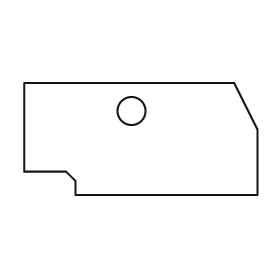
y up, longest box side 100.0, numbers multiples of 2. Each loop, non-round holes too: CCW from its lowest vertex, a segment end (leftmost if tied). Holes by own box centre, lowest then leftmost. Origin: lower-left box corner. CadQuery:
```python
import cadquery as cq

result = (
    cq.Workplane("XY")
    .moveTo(22.0, 0.0)
    .lineTo(100.0, 0.0)
    .lineTo(100.0, 28.0)
    .lineTo(90.0, 48.0)
    .lineTo(0.0, 48.0)
    .lineTo(0.0, 10.0)
    .lineTo(18.0, 10.0)
    .lineTo(22.0, 6.0)
    .close()
    .moveTo(46.0, 36.0)
    .circle(6.0)
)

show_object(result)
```